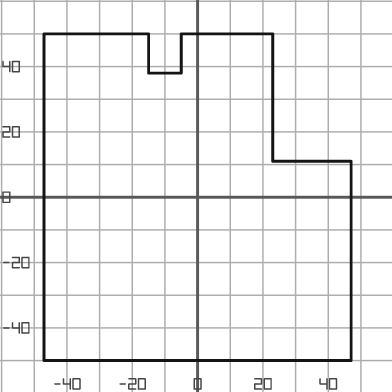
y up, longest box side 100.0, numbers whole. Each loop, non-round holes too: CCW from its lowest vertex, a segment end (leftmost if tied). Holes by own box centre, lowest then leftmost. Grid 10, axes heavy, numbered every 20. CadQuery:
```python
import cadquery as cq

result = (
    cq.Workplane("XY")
    .moveTo(-47.0, -50.0)
    .lineTo(47.0, -50.0)
    .lineTo(47.0, 11.0)
    .lineTo(23.0, 11.0)
    .lineTo(23.0, 50.0)
    .lineTo(-5.0, 50.0)
    .lineTo(-5.0, 38.0)
    .lineTo(-15.0, 38.0)
    .lineTo(-15.0, 50.0)
    .lineTo(-47.0, 50.0)
    .close()
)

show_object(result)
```